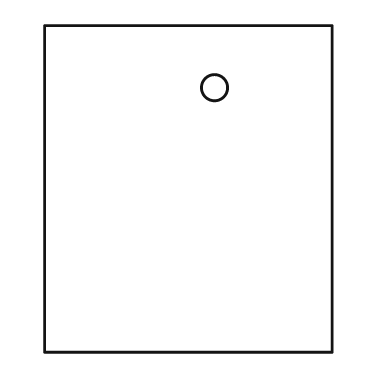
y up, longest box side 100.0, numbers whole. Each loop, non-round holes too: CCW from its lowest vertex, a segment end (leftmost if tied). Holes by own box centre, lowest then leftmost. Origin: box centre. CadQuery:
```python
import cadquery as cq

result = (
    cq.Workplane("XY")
    .moveTo(-44.0, -50.0)
    .lineTo(44.0, -50.0)
    .lineTo(44.0, 50.0)
    .lineTo(-44.0, 50.0)
    .close()
    .moveTo(8.0, 31.0)
    .circle(4.0)
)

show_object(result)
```